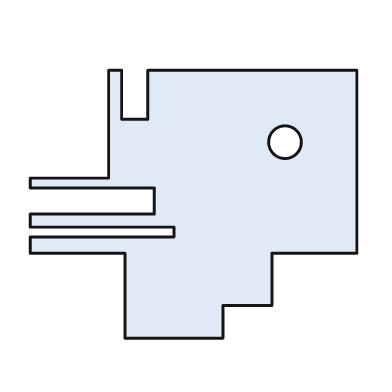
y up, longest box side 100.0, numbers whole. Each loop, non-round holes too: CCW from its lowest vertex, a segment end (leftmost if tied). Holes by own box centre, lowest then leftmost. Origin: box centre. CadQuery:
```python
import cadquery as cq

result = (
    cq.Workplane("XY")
    .moveTo(-21.0, -41.0)
    .lineTo(9.0, -41.0)
    .lineTo(9.0, -31.0)
    .lineTo(24.0, -31.0)
    .lineTo(24.0, -15.0)
    .lineTo(50.0, -15.0)
    .lineTo(50.0, 41.0)
    .lineTo(-14.0, 41.0)
    .lineTo(-14.0, 26.0)
    .lineTo(-22.0, 26.0)
    .lineTo(-22.0, 41.0)
    .lineTo(-26.0, 41.0)
    .lineTo(-26.0, 8.0)
    .lineTo(-50.0, 8.0)
    .lineTo(-50.0, 5.0)
    .lineTo(-12.0, 5.0)
    .lineTo(-12.0, -3.0)
    .lineTo(-50.0, -3.0)
    .lineTo(-50.0, -7.0)
    .lineTo(-6.0, -7.0)
    .lineTo(-6.0, -10.0)
    .lineTo(-50.0, -10.0)
    .lineTo(-50.0, -15.0)
    .lineTo(-21.0, -15.0)
    .close()
    .moveTo(28.0, 19.0)
    .circle(5.0)
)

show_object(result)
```